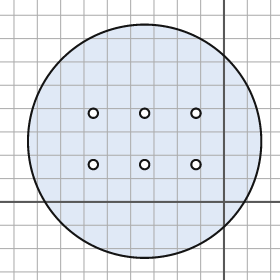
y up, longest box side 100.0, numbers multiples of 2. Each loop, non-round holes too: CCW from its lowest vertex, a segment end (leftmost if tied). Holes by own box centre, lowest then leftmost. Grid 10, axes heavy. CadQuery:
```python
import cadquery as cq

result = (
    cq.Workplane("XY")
    .moveTo(-34.0, 26.0)
    .circle(50.0)
    .moveTo(-56.0, 16.0)
    .circle(2.0)
    .moveTo(-34.0, 16.0)
    .circle(2.0)
    .moveTo(-12.0, 16.0)
    .circle(2.0)
    .moveTo(-56.0, 38.0)
    .circle(2.0)
    .moveTo(-34.0, 38.0)
    .circle(2.0)
    .moveTo(-12.0, 38.0)
    .circle(2.0)
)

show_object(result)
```